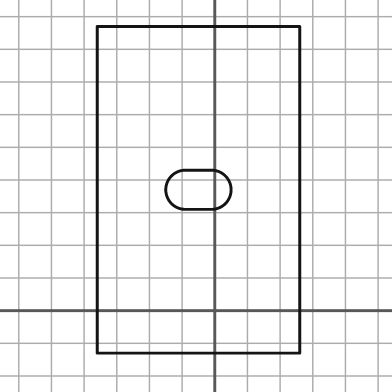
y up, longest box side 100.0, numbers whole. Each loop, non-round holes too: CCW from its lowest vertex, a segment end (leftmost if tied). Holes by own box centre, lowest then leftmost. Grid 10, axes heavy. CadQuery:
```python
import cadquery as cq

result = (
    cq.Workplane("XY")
    .moveTo(-36.0, -13.0)
    .lineTo(26.0, -13.0)
    .lineTo(26.0, 87.0)
    .lineTo(-36.0, 87.0)
    .close()
    .moveTo(-9.0, 31.0)
    .lineTo(-1.0, 31.0)
    .threePointArc((5.0, 37.0), (-1.0, 43.0))
    .lineTo(-9.0, 43.0)
    .threePointArc((-15.0, 37.0), (-9.0, 31.0))
    .close()
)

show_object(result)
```